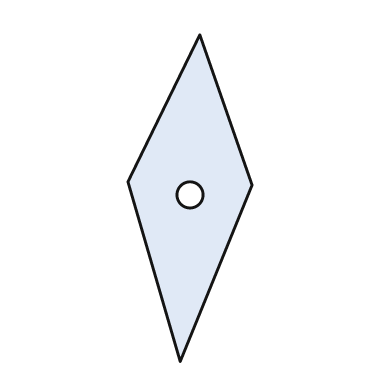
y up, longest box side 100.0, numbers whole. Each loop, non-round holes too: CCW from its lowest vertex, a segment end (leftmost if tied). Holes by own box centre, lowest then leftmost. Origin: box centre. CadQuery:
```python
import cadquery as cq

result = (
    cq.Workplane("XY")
    .moveTo(-3.0, -50.0)
    .lineTo(19.0, 4.0)
    .lineTo(3.0, 50.0)
    .lineTo(-19.0, 5.0)
    .close()
    .moveTo(0.0, 1.0)
    .circle(4.0)
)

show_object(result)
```